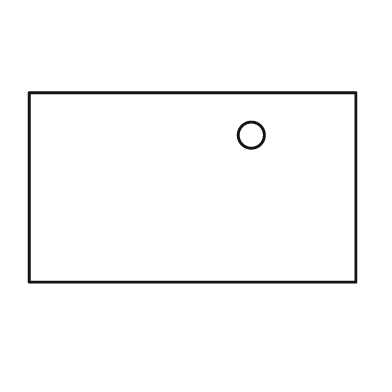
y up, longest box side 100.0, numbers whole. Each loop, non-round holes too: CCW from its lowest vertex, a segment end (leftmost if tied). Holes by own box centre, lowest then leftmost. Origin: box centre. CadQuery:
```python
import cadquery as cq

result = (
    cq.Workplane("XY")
    .moveTo(-50.0, -29.0)
    .lineTo(50.0, -29.0)
    .lineTo(50.0, 29.0)
    .lineTo(-50.0, 29.0)
    .close()
    .moveTo(18.0, 16.0)
    .circle(4.0)
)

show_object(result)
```